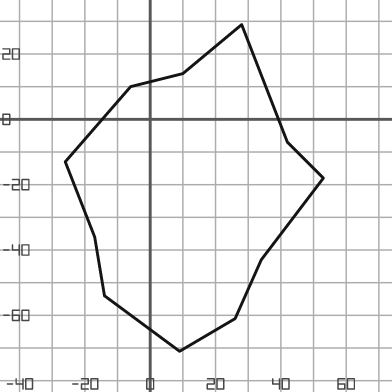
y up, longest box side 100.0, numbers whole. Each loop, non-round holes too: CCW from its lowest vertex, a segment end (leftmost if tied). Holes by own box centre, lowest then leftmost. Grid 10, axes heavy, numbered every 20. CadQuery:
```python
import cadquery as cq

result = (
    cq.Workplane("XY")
    .moveTo(9.0, -71.0)
    .lineTo(26.0, -61.0)
    .lineTo(34.0, -43.0)
    .lineTo(53.0, -18.0)
    .lineTo(42.0, -7.0)
    .lineTo(28.0, 29.0)
    .lineTo(10.0, 14.0)
    .lineTo(-6.0, 10.0)
    .lineTo(-26.0, -13.0)
    .lineTo(-17.0, -36.0)
    .lineTo(-14.0, -54.0)
    .close()
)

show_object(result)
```